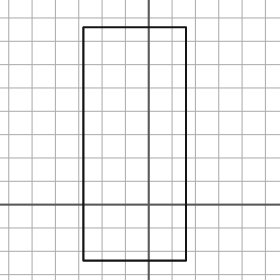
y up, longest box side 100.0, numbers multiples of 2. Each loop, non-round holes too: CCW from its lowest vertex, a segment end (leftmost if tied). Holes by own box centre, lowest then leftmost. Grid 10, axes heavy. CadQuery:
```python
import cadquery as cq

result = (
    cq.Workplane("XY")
    .moveTo(-28.0, -24.0)
    .lineTo(16.0, -24.0)
    .lineTo(16.0, 76.0)
    .lineTo(-28.0, 76.0)
    .close()
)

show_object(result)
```